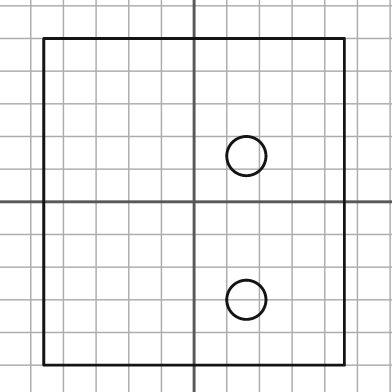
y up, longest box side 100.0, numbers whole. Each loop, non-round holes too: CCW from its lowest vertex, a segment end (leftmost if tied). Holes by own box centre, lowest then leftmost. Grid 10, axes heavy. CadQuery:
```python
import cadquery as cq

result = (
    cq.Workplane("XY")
    .moveTo(-46.0, -50.0)
    .lineTo(46.0, -50.0)
    .lineTo(46.0, 50.0)
    .lineTo(-46.0, 50.0)
    .close()
    .moveTo(16.0, -30.0)
    .circle(6.0)
    .moveTo(16.0, 14.0)
    .circle(6.0)
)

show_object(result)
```